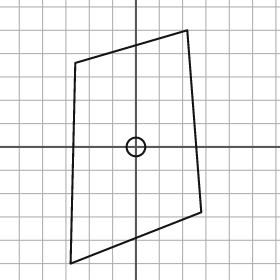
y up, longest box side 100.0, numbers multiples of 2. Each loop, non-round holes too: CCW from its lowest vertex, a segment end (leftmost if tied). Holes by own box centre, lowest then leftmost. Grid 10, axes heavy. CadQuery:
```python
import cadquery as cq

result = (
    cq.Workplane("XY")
    .moveTo(-28.0, -50.0)
    .lineTo(28.0, -28.0)
    .lineTo(22.0, 50.0)
    .lineTo(-26.0, 36.0)
    .close()
    .moveTo(0.0, 0.0)
    .circle(4.0)
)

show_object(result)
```